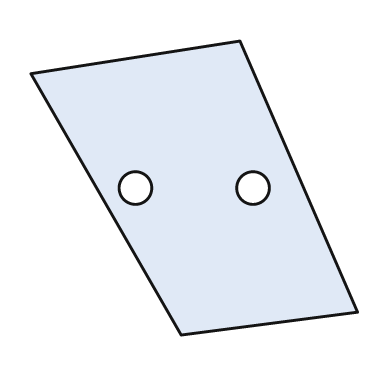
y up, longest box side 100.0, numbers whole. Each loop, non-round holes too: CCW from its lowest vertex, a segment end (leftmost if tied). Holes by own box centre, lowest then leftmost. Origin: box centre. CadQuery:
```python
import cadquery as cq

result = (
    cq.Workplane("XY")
    .moveTo(-4.0, -45.0)
    .lineTo(50.0, -38.0)
    .lineTo(14.0, 45.0)
    .lineTo(-50.0, 35.0)
    .close()
    .moveTo(-18.0, 0.0)
    .circle(5.0)
    .moveTo(18.0, 0.0)
    .circle(5.0)
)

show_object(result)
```